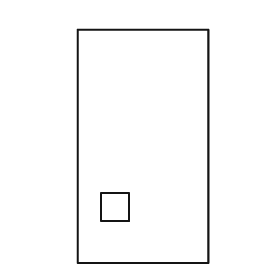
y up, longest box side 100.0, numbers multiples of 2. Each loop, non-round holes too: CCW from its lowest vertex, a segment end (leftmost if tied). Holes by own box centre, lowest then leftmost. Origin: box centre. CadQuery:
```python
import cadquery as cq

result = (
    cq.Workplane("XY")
    .moveTo(-28.0, -50.0)
    .lineTo(28.0, -50.0)
    .lineTo(28.0, 50.0)
    .lineTo(-28.0, 50.0)
    .close()
    .moveTo(-18.0, -32.0)
    .lineTo(-6.0, -32.0)
    .lineTo(-6.0, -20.0)
    .lineTo(-18.0, -20.0)
    .close()
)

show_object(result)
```